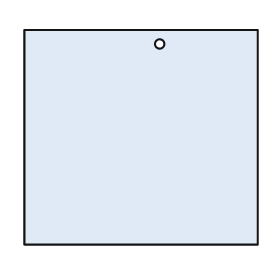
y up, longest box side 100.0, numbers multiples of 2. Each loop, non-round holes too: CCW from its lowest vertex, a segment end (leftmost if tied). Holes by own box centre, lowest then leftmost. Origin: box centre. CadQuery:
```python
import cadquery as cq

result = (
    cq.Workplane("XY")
    .moveTo(-50.0, -46.0)
    .lineTo(50.0, -46.0)
    .lineTo(50.0, 46.0)
    .lineTo(-50.0, 46.0)
    .close()
    .moveTo(8.0, 40.0)
    .circle(2.0)
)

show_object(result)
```